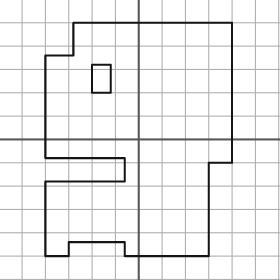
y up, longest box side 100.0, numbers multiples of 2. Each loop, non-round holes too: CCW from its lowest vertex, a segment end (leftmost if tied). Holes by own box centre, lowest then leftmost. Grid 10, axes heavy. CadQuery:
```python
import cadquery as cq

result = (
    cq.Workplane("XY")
    .moveTo(-40.0, -50.0)
    .lineTo(-30.0, -50.0)
    .lineTo(-30.0, -44.0)
    .lineTo(-6.0, -44.0)
    .lineTo(-6.0, -50.0)
    .lineTo(30.0, -50.0)
    .lineTo(30.0, -10.0)
    .lineTo(40.0, -10.0)
    .lineTo(40.0, 50.0)
    .lineTo(-28.0, 50.0)
    .lineTo(-28.0, 36.0)
    .lineTo(-40.0, 36.0)
    .lineTo(-40.0, -8.0)
    .lineTo(-6.0, -8.0)
    .lineTo(-6.0, -18.0)
    .lineTo(-40.0, -18.0)
    .close()
    .moveTo(-20.0, 20.0)
    .lineTo(-12.0, 20.0)
    .lineTo(-12.0, 32.0)
    .lineTo(-20.0, 32.0)
    .close()
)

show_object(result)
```